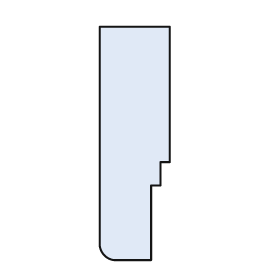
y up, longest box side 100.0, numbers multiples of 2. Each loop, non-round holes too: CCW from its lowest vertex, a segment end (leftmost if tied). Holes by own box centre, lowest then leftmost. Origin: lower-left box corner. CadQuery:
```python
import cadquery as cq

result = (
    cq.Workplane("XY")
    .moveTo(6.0, 0.0)
    .lineTo(22.0, 0.0)
    .lineTo(22.0, 32.0)
    .lineTo(26.0, 32.0)
    .lineTo(26.0, 42.0)
    .lineTo(30.0, 42.0)
    .lineTo(30.0, 100.0)
    .lineTo(0.0, 100.0)
    .lineTo(0.0, 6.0)
    .threePointArc((2.0, 2.0), (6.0, 0.0))
    .close()
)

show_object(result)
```